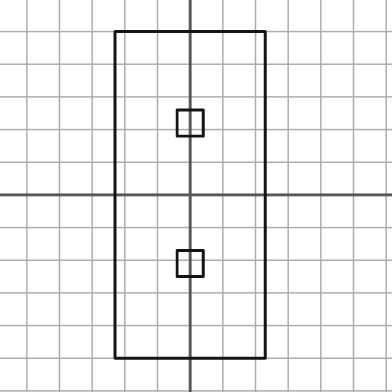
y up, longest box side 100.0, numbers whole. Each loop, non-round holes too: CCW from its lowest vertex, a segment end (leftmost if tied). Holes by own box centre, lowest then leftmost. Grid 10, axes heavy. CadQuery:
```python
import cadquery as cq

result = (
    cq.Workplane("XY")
    .moveTo(-23.0, -50.0)
    .lineTo(23.0, -50.0)
    .lineTo(23.0, 50.0)
    .lineTo(-23.0, 50.0)
    .close()
    .moveTo(-4.0, -25.0)
    .lineTo(4.0, -25.0)
    .lineTo(4.0, -17.0)
    .lineTo(-4.0, -17.0)
    .close()
    .moveTo(-4.0, 18.0)
    .lineTo(4.0, 18.0)
    .lineTo(4.0, 26.0)
    .lineTo(-4.0, 26.0)
    .close()
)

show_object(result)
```